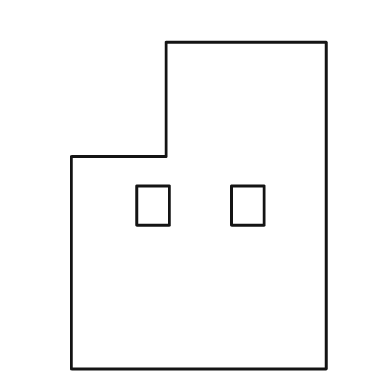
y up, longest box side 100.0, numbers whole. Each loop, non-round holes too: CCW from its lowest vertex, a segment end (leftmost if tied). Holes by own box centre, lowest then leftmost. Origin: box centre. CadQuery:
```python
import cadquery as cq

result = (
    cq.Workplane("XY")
    .moveTo(-39.0, -50.0)
    .lineTo(39.0, -50.0)
    .lineTo(39.0, 50.0)
    .lineTo(-10.0, 50.0)
    .lineTo(-10.0, 15.0)
    .lineTo(-39.0, 15.0)
    .close()
    .moveTo(-19.0, -6.0)
    .lineTo(-9.0, -6.0)
    .lineTo(-9.0, 6.0)
    .lineTo(-19.0, 6.0)
    .close()
    .moveTo(10.0, -6.0)
    .lineTo(20.0, -6.0)
    .lineTo(20.0, 6.0)
    .lineTo(10.0, 6.0)
    .close()
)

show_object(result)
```